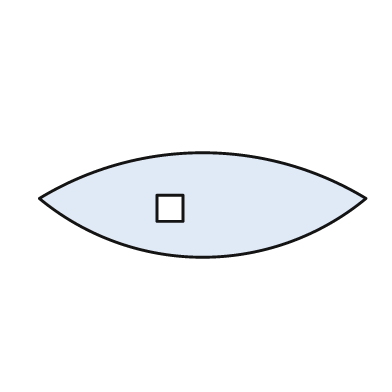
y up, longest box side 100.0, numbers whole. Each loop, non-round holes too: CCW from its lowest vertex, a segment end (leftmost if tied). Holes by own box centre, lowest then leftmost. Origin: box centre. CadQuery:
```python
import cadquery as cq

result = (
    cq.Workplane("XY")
    .moveTo(-50.0, 2.0)
    .threePointArc((0.0, -16.0), (50.0, 2.0))
    .threePointArc((0.0, 16.0), (-50.0, 2.0))
    .close()
    .moveTo(-14.0, -5.0)
    .lineTo(-6.0, -5.0)
    .lineTo(-6.0, 3.0)
    .lineTo(-14.0, 3.0)
    .close()
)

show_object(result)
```